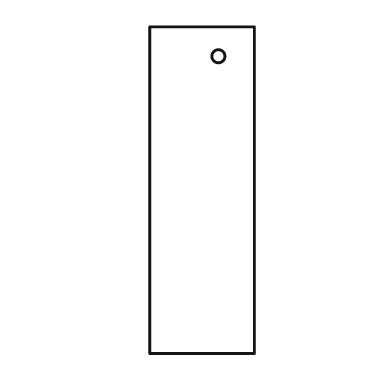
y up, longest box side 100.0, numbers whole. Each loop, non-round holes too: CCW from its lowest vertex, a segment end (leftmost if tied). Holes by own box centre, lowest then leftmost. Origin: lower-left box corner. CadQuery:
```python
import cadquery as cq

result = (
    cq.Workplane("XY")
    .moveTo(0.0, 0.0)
    .lineTo(32.0, 0.0)
    .lineTo(32.0, 100.0)
    .lineTo(0.0, 100.0)
    .close()
    .moveTo(21.0, 91.0)
    .circle(2.0)
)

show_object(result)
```